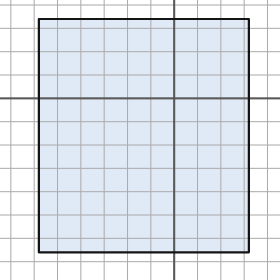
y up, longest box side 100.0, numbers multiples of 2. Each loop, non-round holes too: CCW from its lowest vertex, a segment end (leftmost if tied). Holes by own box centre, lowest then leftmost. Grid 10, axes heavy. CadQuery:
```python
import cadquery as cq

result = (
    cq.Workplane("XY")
    .moveTo(-58.0, -66.0)
    .lineTo(32.0, -66.0)
    .lineTo(32.0, 34.0)
    .lineTo(-58.0, 34.0)
    .close()
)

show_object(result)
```